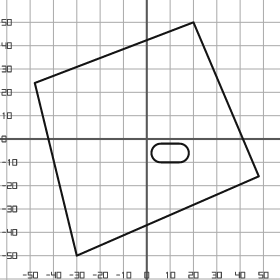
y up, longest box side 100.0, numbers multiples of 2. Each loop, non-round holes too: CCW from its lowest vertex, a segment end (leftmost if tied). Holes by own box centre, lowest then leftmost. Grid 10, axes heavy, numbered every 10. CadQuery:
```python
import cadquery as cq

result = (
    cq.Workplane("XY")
    .moveTo(-30.0, -50.0)
    .lineTo(48.0, -16.0)
    .lineTo(20.0, 50.0)
    .lineTo(-48.0, 24.0)
    .close()
    .moveTo(6.0, -10.0)
    .lineTo(14.0, -10.0)
    .threePointArc((18.0, -6.0), (14.0, -2.0))
    .lineTo(6.0, -2.0)
    .threePointArc((2.0, -6.0), (6.0, -10.0))
    .close()
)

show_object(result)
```